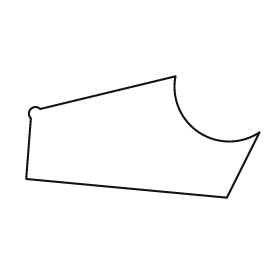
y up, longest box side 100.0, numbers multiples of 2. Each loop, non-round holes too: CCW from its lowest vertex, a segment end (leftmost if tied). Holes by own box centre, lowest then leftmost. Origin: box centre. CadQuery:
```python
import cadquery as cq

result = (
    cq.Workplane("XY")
    .moveTo(36.0, -26.0)
    .lineTo(50.0, 2.0)
    .threePointArc((24.0, 2.0), (14.0, 26.0))
    .lineTo(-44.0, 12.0)
    .threePointArc((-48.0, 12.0), (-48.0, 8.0))
    .lineTo(-50.0, -18.0)
    .close()
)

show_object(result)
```